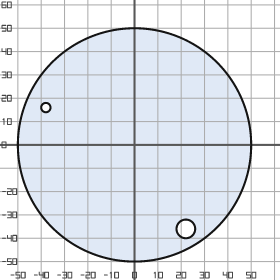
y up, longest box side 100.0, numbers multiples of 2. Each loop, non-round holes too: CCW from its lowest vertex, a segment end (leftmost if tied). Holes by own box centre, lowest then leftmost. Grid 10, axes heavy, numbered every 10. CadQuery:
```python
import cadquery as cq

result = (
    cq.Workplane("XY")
    .moveTo(0.0, 0.0)
    .circle(50.0)
    .moveTo(22.0, -36.0)
    .circle(4.0)
    .moveTo(-38.0, 16.0)
    .circle(2.0)
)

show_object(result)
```